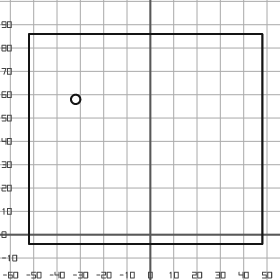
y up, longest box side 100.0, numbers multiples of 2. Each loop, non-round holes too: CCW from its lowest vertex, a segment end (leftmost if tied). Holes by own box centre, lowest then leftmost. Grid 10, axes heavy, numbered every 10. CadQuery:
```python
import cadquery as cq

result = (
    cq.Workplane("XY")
    .moveTo(-52.0, -4.0)
    .lineTo(48.0, -4.0)
    .lineTo(48.0, 86.0)
    .lineTo(-52.0, 86.0)
    .close()
    .moveTo(-32.0, 58.0)
    .circle(2.0)
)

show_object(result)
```